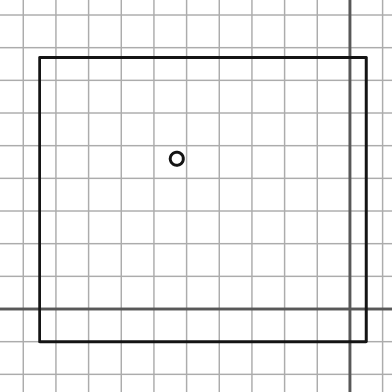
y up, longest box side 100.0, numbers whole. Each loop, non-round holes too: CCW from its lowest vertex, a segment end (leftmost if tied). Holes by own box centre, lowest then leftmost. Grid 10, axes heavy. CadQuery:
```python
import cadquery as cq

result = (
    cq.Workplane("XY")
    .moveTo(-95.0, -10.0)
    .lineTo(5.0, -10.0)
    .lineTo(5.0, 77.0)
    .lineTo(-95.0, 77.0)
    .close()
    .moveTo(-53.0, 46.0)
    .circle(2.0)
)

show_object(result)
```